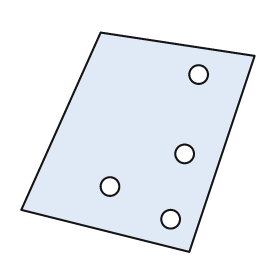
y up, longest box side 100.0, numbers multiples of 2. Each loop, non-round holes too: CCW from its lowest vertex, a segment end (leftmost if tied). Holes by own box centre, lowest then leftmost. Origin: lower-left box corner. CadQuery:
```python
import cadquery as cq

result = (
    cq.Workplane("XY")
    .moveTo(72.0, 0.0)
    .lineTo(100.0, 84.0)
    .lineTo(34.0, 94.0)
    .lineTo(0.0, 18.0)
    .close()
    .moveTo(64.0, 14.0)
    .circle(4.0)
    .moveTo(38.0, 28.0)
    .circle(4.0)
    .moveTo(70.0, 42.0)
    .circle(4.0)
    .moveTo(76.0, 76.0)
    .circle(4.0)
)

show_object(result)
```